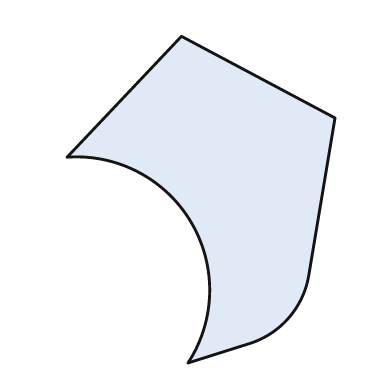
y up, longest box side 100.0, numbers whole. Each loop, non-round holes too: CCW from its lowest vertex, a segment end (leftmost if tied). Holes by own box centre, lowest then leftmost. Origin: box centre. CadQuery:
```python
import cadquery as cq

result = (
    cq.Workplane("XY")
    .moveTo(-4.0, -50.0)
    .lineTo(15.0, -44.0)
    .threePointArc((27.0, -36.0), (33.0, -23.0))
    .lineTo(41.0, 25.0)
    .lineTo(-6.0, 50.0)
    .lineTo(-41.0, 13.0)
    .threePointArc((-3.0, -7.0), (-4.0, -50.0))
    .close()
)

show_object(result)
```